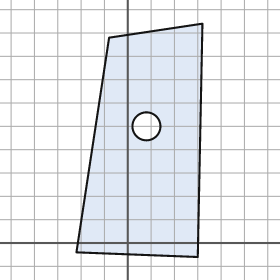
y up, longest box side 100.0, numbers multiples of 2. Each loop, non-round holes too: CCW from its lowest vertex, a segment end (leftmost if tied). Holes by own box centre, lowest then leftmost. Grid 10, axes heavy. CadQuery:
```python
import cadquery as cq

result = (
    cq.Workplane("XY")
    .moveTo(30.0, -6.0)
    .lineTo(32.0, 94.0)
    .lineTo(-8.0, 88.0)
    .lineTo(-22.0, -4.0)
    .close()
    .moveTo(8.0, 50.0)
    .circle(6.0)
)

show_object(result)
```